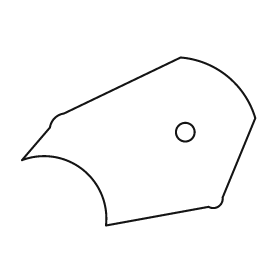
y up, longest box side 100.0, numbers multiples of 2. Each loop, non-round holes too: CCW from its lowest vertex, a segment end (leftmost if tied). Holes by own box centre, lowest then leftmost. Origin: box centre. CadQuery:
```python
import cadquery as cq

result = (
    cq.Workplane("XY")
    .moveTo(-14.0, -36.0)
    .lineTo(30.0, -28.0)
    .threePointArc((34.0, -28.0), (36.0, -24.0))
    .lineTo(50.0, 10.0)
    .threePointArc((38.0, 28.0), (18.0, 36.0))
    .lineTo(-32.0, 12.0)
    .threePointArc((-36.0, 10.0), (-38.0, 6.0))
    .lineTo(-50.0, -8.0)
    .threePointArc((-24.0, -12.0), (-14.0, -36.0))
    .close()
    .moveTo(20.0, 4.0)
    .circle(4.0)
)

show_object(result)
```